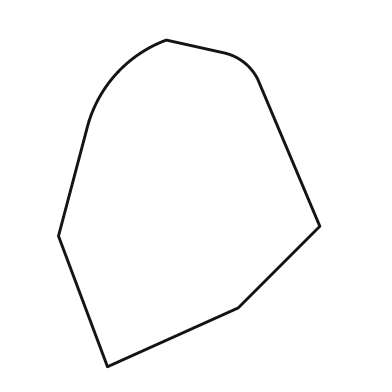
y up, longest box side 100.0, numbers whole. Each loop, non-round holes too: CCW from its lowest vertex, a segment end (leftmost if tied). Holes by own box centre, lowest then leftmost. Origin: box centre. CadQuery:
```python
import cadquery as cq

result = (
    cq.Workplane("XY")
    .moveTo(-25.0, -50.0)
    .lineTo(15.0, -32.0)
    .lineTo(40.0, -7.0)
    .lineTo(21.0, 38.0)
    .threePointArc((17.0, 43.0), (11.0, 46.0))
    .lineTo(-7.0, 50.0)
    .threePointArc((-22.0, 40.0), (-31.0, 24.0))
    .lineTo(-40.0, -10.0)
    .close()
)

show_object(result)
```